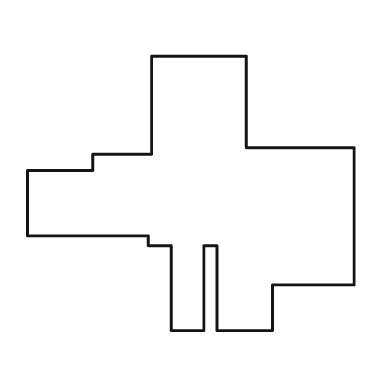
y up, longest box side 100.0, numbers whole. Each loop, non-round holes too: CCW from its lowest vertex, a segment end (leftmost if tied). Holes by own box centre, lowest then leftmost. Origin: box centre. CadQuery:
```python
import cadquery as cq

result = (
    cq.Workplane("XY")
    .moveTo(-6.0, -42.0)
    .lineTo(4.0, -42.0)
    .lineTo(4.0, -16.0)
    .lineTo(8.0, -16.0)
    .lineTo(8.0, -42.0)
    .lineTo(25.0, -42.0)
    .lineTo(25.0, -28.0)
    .lineTo(50.0, -28.0)
    .lineTo(50.0, 14.0)
    .lineTo(17.0, 14.0)
    .lineTo(17.0, 42.0)
    .lineTo(-12.0, 42.0)
    .lineTo(-12.0, 12.0)
    .lineTo(-30.0, 12.0)
    .lineTo(-30.0, 7.0)
    .lineTo(-50.0, 7.0)
    .lineTo(-50.0, -13.0)
    .lineTo(-13.0, -13.0)
    .lineTo(-13.0, -16.0)
    .lineTo(-6.0, -16.0)
    .close()
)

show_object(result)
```